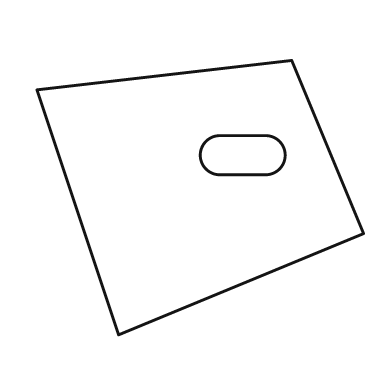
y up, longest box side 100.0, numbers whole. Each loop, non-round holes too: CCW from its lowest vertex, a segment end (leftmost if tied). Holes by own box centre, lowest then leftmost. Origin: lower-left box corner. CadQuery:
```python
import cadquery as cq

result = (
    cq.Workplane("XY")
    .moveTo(25.0, 0.0)
    .lineTo(100.0, 31.0)
    .lineTo(78.0, 84.0)
    .lineTo(0.0, 75.0)
    .close()
    .moveTo(56.0, 49.0)
    .lineTo(70.0, 49.0)
    .threePointArc((76.0, 55.0), (70.0, 61.0))
    .lineTo(56.0, 61.0)
    .threePointArc((50.0, 55.0), (56.0, 49.0))
    .close()
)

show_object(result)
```